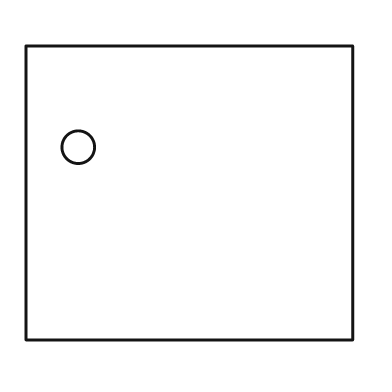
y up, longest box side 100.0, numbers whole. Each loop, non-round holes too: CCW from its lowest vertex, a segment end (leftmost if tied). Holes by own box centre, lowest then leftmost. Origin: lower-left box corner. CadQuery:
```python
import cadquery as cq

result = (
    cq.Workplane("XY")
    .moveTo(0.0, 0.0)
    .lineTo(100.0, 0.0)
    .lineTo(100.0, 90.0)
    .lineTo(0.0, 90.0)
    .close()
    .moveTo(16.0, 59.0)
    .circle(5.0)
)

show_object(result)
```